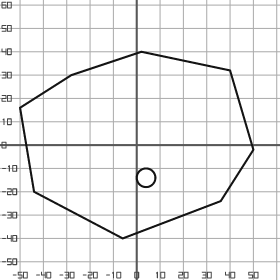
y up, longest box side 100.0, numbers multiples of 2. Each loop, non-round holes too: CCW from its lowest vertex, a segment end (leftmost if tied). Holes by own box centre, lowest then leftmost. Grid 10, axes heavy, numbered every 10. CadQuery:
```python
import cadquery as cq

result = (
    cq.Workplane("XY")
    .moveTo(-6.0, -40.0)
    .lineTo(36.0, -24.0)
    .lineTo(50.0, -2.0)
    .lineTo(40.0, 32.0)
    .lineTo(2.0, 40.0)
    .lineTo(-28.0, 30.0)
    .lineTo(-50.0, 16.0)
    .lineTo(-44.0, -20.0)
    .close()
    .moveTo(4.0, -14.0)
    .circle(4.0)
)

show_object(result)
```